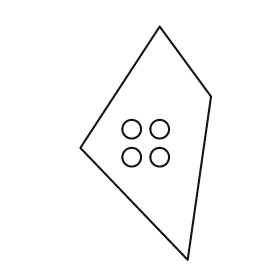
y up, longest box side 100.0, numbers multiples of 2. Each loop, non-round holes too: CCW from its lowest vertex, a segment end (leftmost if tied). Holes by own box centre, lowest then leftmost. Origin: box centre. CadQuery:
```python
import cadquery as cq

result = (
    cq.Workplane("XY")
    .moveTo(18.0, -50.0)
    .lineTo(28.0, 20.0)
    .lineTo(6.0, 50.0)
    .lineTo(-28.0, -2.0)
    .close()
    .moveTo(-6.0, -6.0)
    .circle(4.0)
    .moveTo(6.0, -6.0)
    .circle(4.0)
    .moveTo(-6.0, 6.0)
    .circle(4.0)
    .moveTo(6.0, 6.0)
    .circle(4.0)
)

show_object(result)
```